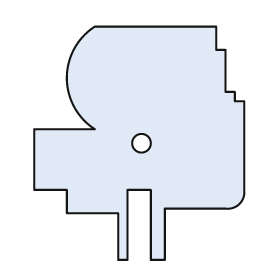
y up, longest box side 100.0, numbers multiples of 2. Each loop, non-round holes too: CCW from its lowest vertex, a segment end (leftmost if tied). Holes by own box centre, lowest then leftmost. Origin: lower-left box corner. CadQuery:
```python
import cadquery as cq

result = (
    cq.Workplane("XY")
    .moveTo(36.0, 0.0)
    .lineTo(40.0, 0.0)
    .lineTo(40.0, 30.0)
    .lineTo(50.0, 30.0)
    .lineTo(50.0, 0.0)
    .lineTo(56.0, 0.0)
    .lineTo(56.0, 22.0)
    .lineTo(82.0, 22.0)
    .threePointArc((88.0, 24.0), (90.0, 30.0))
    .lineTo(90.0, 68.0)
    .lineTo(86.0, 68.0)
    .lineTo(86.0, 72.0)
    .lineTo(82.0, 72.0)
    .lineTo(82.0, 90.0)
    .lineTo(78.0, 90.0)
    .lineTo(78.0, 100.0)
    .lineTo(26.0, 100.0)
    .threePointArc((14.0, 78.0), (26.0, 56.0))
    .lineTo(0.0, 56.0)
    .lineTo(0.0, 30.0)
    .lineTo(14.0, 30.0)
    .lineTo(14.0, 20.0)
    .lineTo(36.0, 20.0)
    .close()
    .moveTo(46.0, 50.0)
    .circle(4.0)
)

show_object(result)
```